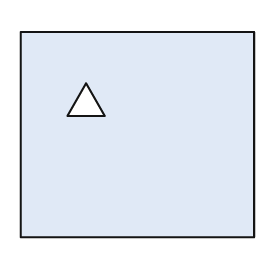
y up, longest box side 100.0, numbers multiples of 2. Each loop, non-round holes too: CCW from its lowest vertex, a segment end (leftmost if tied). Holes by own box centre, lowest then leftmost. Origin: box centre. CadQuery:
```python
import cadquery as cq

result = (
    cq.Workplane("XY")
    .moveTo(-50.0, -44.0)
    .lineTo(50.0, -44.0)
    .lineTo(50.0, 44.0)
    .lineTo(-50.0, 44.0)
    .close()
    .moveTo(-30.0, 8.0)
    .lineTo(-14.0, 8.0)
    .lineTo(-22.0, 22.0)
    .close()
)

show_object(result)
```